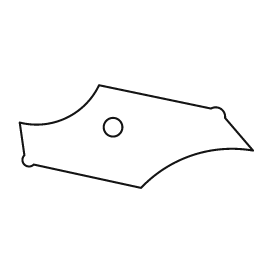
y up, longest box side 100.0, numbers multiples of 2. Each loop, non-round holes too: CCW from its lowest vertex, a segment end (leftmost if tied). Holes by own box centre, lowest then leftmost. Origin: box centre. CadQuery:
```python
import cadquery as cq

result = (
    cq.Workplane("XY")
    .moveTo(2.0, -22.0)
    .threePointArc((24.0, -8.0), (50.0, -6.0))
    .lineTo(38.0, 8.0)
    .threePointArc((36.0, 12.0), (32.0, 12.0))
    .lineTo(-16.0, 22.0)
    .threePointArc((-30.0, 8.0), (-50.0, 6.0))
    .lineTo(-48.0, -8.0)
    .threePointArc((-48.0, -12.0), (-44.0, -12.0))
    .close()
    .moveTo(-10.0, 4.0)
    .circle(4.0)
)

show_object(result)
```